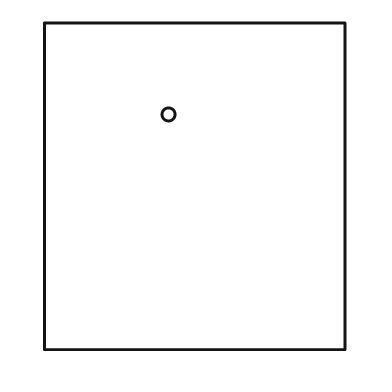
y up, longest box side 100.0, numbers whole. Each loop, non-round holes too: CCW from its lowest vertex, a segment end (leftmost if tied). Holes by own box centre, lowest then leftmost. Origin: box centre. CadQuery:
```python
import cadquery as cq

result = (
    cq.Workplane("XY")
    .moveTo(-46.0, -50.0)
    .lineTo(46.0, -50.0)
    .lineTo(46.0, 50.0)
    .lineTo(-46.0, 50.0)
    .close()
    .moveTo(-8.0, 22.0)
    .circle(2.0)
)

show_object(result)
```